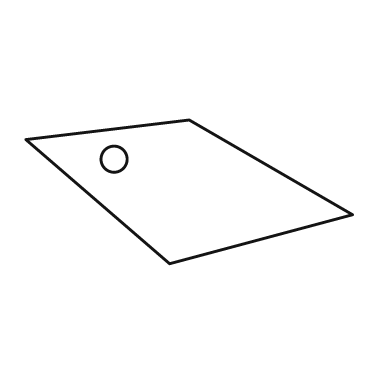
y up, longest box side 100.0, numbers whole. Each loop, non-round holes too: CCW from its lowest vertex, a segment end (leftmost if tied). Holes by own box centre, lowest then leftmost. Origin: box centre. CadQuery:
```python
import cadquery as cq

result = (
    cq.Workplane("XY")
    .moveTo(-6.0, -22.0)
    .lineTo(50.0, -7.0)
    .lineTo(0.0, 22.0)
    .lineTo(-50.0, 16.0)
    .close()
    .moveTo(-23.0, 10.0)
    .circle(4.0)
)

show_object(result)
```